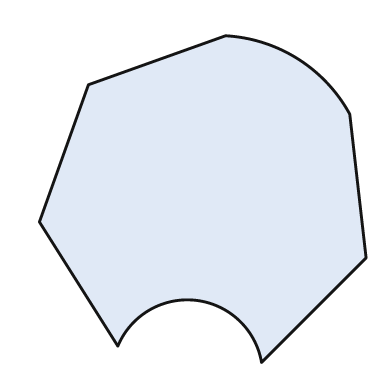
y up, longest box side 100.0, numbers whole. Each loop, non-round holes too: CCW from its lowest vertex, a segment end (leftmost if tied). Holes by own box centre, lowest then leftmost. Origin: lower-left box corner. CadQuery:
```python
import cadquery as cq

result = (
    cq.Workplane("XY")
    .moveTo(68.0, 0.0)
    .lineTo(100.0, 32.0)
    .lineTo(95.0, 76.0)
    .threePointArc((79.0, 93.0), (57.0, 100.0))
    .lineTo(15.0, 85.0)
    .lineTo(0.0, 43.0)
    .lineTo(24.0, 5.0)
    .threePointArc((48.0, 19.0), (68.0, 0.0))
    .close()
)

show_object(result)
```